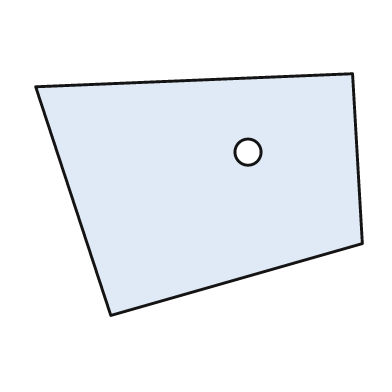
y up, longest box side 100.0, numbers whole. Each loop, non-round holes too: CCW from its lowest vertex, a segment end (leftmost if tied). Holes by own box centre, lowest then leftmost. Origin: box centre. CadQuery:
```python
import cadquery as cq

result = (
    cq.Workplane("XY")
    .moveTo(-27.0, -37.0)
    .lineTo(50.0, -15.0)
    .lineTo(47.0, 37.0)
    .lineTo(-50.0, 33.0)
    .close()
    .moveTo(15.0, 13.0)
    .circle(4.0)
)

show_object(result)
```